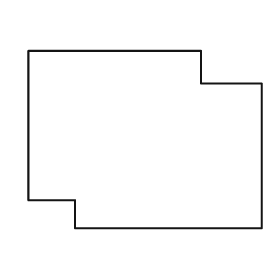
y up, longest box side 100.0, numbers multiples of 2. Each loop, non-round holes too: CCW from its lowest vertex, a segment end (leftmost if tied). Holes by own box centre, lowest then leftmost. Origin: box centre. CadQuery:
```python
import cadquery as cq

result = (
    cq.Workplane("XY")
    .moveTo(-30.0, -38.0)
    .lineTo(50.0, -38.0)
    .lineTo(50.0, 24.0)
    .lineTo(24.0, 24.0)
    .lineTo(24.0, 38.0)
    .lineTo(-50.0, 38.0)
    .lineTo(-50.0, -26.0)
    .lineTo(-30.0, -26.0)
    .close()
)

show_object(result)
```